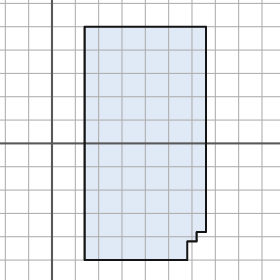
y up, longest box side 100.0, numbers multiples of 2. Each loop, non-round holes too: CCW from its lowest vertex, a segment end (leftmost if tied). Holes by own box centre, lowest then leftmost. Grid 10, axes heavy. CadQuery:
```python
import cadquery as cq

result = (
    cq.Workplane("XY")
    .moveTo(14.0, -50.0)
    .lineTo(58.0, -50.0)
    .lineTo(58.0, -42.0)
    .lineTo(62.0, -42.0)
    .lineTo(62.0, -38.0)
    .lineTo(66.0, -38.0)
    .lineTo(66.0, 50.0)
    .lineTo(14.0, 50.0)
    .close()
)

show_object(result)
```